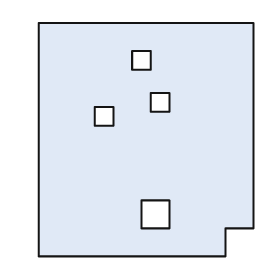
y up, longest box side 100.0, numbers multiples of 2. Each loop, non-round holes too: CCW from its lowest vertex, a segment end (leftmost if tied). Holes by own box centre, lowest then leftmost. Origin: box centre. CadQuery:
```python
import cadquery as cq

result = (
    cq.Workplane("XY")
    .moveTo(-46.0, -50.0)
    .lineTo(34.0, -50.0)
    .lineTo(34.0, -38.0)
    .lineTo(46.0, -38.0)
    .lineTo(46.0, 50.0)
    .lineTo(-46.0, 50.0)
    .close()
    .moveTo(-2.0, -38.0)
    .lineTo(10.0, -38.0)
    .lineTo(10.0, -26.0)
    .lineTo(-2.0, -26.0)
    .close()
    .moveTo(-22.0, 6.0)
    .lineTo(-14.0, 6.0)
    .lineTo(-14.0, 14.0)
    .lineTo(-22.0, 14.0)
    .close()
    .moveTo(2.0, 12.0)
    .lineTo(10.0, 12.0)
    .lineTo(10.0, 20.0)
    .lineTo(2.0, 20.0)
    .close()
    .moveTo(-6.0, 30.0)
    .lineTo(2.0, 30.0)
    .lineTo(2.0, 38.0)
    .lineTo(-6.0, 38.0)
    .close()
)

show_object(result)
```